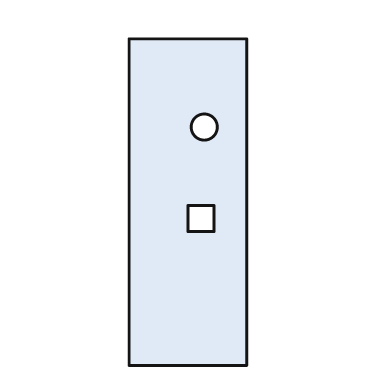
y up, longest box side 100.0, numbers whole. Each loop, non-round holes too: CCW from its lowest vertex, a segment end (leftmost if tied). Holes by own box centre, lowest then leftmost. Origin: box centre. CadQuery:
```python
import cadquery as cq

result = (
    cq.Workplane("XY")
    .moveTo(-18.0, -50.0)
    .lineTo(18.0, -50.0)
    .lineTo(18.0, 50.0)
    .lineTo(-18.0, 50.0)
    .close()
    .moveTo(0.0, -9.0)
    .lineTo(8.0, -9.0)
    .lineTo(8.0, -1.0)
    .lineTo(0.0, -1.0)
    .close()
    .moveTo(5.0, 23.0)
    .circle(4.0)
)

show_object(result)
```